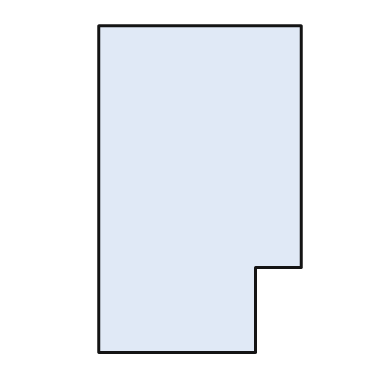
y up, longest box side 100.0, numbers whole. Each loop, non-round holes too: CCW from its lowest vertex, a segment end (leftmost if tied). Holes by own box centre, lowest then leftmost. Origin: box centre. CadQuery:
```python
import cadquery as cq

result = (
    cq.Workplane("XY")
    .moveTo(-31.0, -50.0)
    .lineTo(17.0, -50.0)
    .lineTo(17.0, -24.0)
    .lineTo(31.0, -24.0)
    .lineTo(31.0, 50.0)
    .lineTo(-31.0, 50.0)
    .close()
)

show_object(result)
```